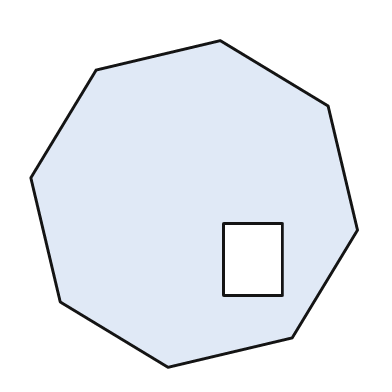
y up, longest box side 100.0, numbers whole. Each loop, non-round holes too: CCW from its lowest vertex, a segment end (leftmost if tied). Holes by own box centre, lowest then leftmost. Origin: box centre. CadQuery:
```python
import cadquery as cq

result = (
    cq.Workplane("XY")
    .moveTo(-8.0, -50.0)
    .lineTo(30.0, -41.0)
    .lineTo(50.0, -8.0)
    .lineTo(41.0, 30.0)
    .lineTo(8.0, 50.0)
    .lineTo(-30.0, 41.0)
    .lineTo(-50.0, 8.0)
    .lineTo(-41.0, -30.0)
    .close()
    .moveTo(9.0, -28.0)
    .lineTo(27.0, -28.0)
    .lineTo(27.0, -6.0)
    .lineTo(9.0, -6.0)
    .close()
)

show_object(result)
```